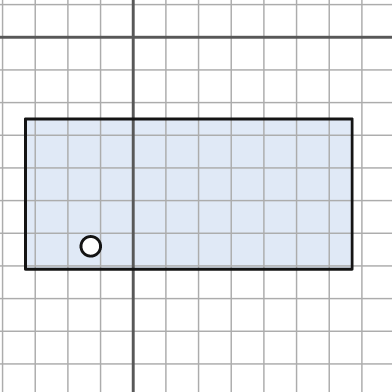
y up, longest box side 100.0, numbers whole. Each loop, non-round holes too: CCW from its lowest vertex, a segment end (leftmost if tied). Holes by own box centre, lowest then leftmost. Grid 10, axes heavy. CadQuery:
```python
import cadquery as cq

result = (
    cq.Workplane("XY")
    .moveTo(-33.0, -71.0)
    .lineTo(67.0, -71.0)
    .lineTo(67.0, -25.0)
    .lineTo(-33.0, -25.0)
    .close()
    .moveTo(-13.0, -64.0)
    .circle(3.0)
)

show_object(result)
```